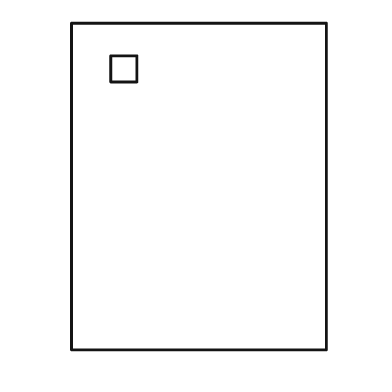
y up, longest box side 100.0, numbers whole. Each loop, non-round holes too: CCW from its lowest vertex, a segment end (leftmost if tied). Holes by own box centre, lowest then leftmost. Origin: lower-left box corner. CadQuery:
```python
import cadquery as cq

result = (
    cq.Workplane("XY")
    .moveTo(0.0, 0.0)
    .lineTo(78.0, 0.0)
    .lineTo(78.0, 100.0)
    .lineTo(0.0, 100.0)
    .close()
    .moveTo(12.0, 82.0)
    .lineTo(20.0, 82.0)
    .lineTo(20.0, 90.0)
    .lineTo(12.0, 90.0)
    .close()
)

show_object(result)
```